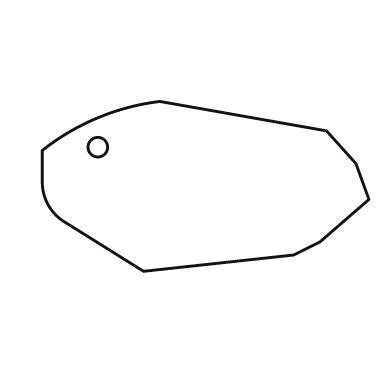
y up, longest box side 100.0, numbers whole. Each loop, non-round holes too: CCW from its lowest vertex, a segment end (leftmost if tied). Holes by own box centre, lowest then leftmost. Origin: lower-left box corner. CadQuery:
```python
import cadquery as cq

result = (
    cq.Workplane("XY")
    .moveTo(31.0, 0.0)
    .lineTo(77.0, 5.0)
    .lineTo(85.0, 9.0)
    .lineTo(100.0, 22.0)
    .lineTo(96.0, 33.0)
    .lineTo(87.0, 43.0)
    .lineTo(36.0, 52.0)
    .threePointArc((17.0, 47.0), (0.0, 37.0))
    .lineTo(0.0, 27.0)
    .threePointArc((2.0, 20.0), (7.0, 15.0))
    .close()
    .moveTo(17.0, 38.0)
    .circle(3.0)
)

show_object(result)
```